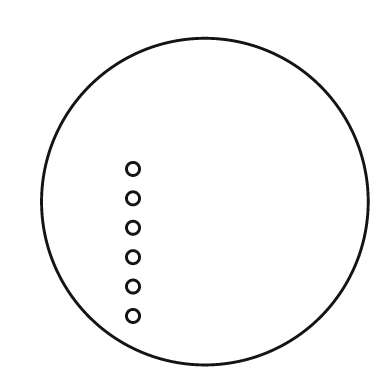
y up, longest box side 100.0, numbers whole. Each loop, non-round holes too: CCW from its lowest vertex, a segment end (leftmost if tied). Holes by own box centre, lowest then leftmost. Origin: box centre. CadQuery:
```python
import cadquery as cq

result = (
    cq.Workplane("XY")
    .moveTo(0.0, 0.0)
    .circle(50.0)
    .moveTo(-22.0, -35.0)
    .circle(2.0)
    .moveTo(-22.0, -26.0)
    .circle(2.0)
    .moveTo(-22.0, -17.0)
    .circle(2.0)
    .moveTo(-22.0, -8.0)
    .circle(2.0)
    .moveTo(-22.0, 1.0)
    .circle(2.0)
    .moveTo(-22.0, 10.0)
    .circle(2.0)
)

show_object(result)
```